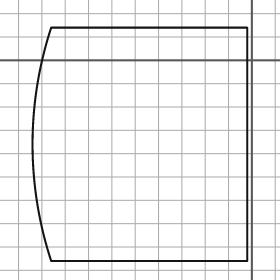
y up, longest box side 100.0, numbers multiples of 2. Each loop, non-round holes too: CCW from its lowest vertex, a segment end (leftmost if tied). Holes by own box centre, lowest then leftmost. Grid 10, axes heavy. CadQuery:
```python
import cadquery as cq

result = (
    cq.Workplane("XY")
    .moveTo(-86.0, -86.0)
    .lineTo(-2.0, -86.0)
    .lineTo(-2.0, 14.0)
    .lineTo(-86.0, 14.0)
    .threePointArc((-94.0, -36.0), (-86.0, -86.0))
    .close()
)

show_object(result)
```